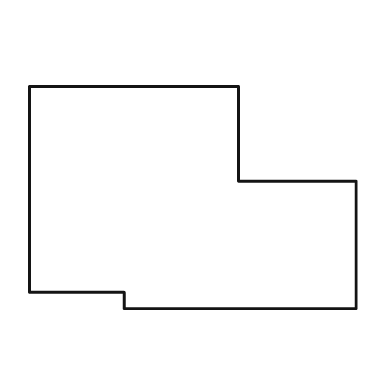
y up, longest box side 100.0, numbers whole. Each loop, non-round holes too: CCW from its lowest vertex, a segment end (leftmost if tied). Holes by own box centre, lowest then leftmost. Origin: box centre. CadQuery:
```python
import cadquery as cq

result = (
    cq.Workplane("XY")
    .moveTo(-21.0, -34.0)
    .lineTo(50.0, -34.0)
    .lineTo(50.0, 5.0)
    .lineTo(14.0, 5.0)
    .lineTo(14.0, 34.0)
    .lineTo(-50.0, 34.0)
    .lineTo(-50.0, -29.0)
    .lineTo(-21.0, -29.0)
    .close()
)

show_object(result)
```